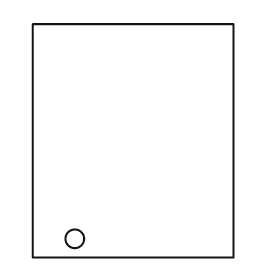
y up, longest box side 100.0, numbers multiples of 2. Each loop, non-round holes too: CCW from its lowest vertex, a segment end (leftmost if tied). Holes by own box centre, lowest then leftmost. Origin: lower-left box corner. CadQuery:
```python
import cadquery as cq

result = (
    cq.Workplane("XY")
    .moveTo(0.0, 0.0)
    .lineTo(86.0, 0.0)
    .lineTo(86.0, 100.0)
    .lineTo(0.0, 100.0)
    .close()
    .moveTo(18.0, 8.0)
    .circle(4.0)
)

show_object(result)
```